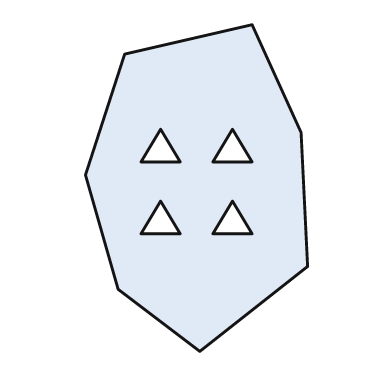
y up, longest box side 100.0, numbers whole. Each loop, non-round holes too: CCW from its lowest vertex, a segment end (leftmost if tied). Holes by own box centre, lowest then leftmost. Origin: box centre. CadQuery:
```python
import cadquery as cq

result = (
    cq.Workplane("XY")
    .moveTo(1.0, -50.0)
    .lineTo(34.0, -24.0)
    .lineTo(32.0, 17.0)
    .lineTo(17.0, 50.0)
    .lineTo(-22.0, 41.0)
    .lineTo(-34.0, 4.0)
    .lineTo(-24.0, -31.0)
    .close()
    .moveTo(-17.0, -14.0)
    .lineTo(-5.0, -14.0)
    .lineTo(-11.0, -4.0)
    .close()
    .moveTo(5.0, -14.0)
    .lineTo(17.0, -14.0)
    .lineTo(11.0, -4.0)
    .close()
    .moveTo(-17.0, 8.0)
    .lineTo(-5.0, 8.0)
    .lineTo(-11.0, 18.0)
    .close()
    .moveTo(5.0, 8.0)
    .lineTo(17.0, 8.0)
    .lineTo(11.0, 18.0)
    .close()
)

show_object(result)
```